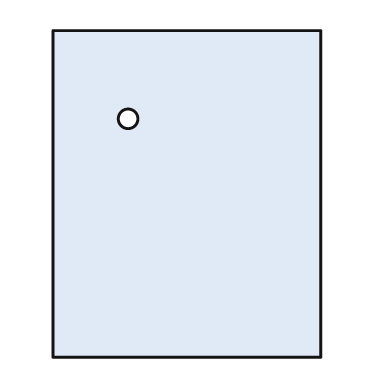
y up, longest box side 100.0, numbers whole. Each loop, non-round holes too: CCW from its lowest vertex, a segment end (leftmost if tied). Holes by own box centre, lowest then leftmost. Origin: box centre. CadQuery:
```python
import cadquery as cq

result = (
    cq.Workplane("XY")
    .moveTo(-41.0, -50.0)
    .lineTo(41.0, -50.0)
    .lineTo(41.0, 50.0)
    .lineTo(-41.0, 50.0)
    .close()
    .moveTo(-18.0, 23.0)
    .circle(3.0)
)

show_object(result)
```